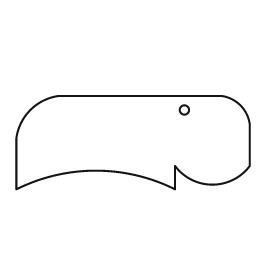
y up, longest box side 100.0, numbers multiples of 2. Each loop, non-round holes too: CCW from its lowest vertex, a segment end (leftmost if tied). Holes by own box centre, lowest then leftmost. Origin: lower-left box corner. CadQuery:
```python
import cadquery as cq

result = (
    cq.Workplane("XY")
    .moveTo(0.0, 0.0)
    .threePointArc((34.0, 8.0), (68.0, 0.0))
    .lineTo(68.0, 10.0)
    .threePointArc((84.0, 2.0), (100.0, 10.0))
    .lineTo(100.0, 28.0)
    .threePointArc((96.0, 36.0), (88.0, 40.0))
    .lineTo(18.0, 40.0)
    .threePointArc((6.0, 34.0), (0.0, 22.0))
    .close()
    .moveTo(72.0, 34.0)
    .circle(2.0)
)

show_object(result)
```